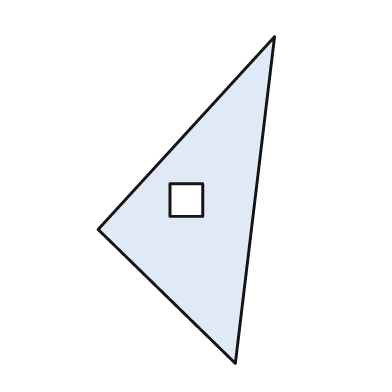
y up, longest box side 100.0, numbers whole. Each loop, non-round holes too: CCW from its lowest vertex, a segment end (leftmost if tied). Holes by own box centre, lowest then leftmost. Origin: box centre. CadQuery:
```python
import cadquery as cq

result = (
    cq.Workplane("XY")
    .moveTo(15.0, -50.0)
    .lineTo(27.0, 50.0)
    .lineTo(-27.0, -9.0)
    .close()
    .moveTo(-5.0, -5.0)
    .lineTo(5.0, -5.0)
    .lineTo(5.0, 5.0)
    .lineTo(-5.0, 5.0)
    .close()
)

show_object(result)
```